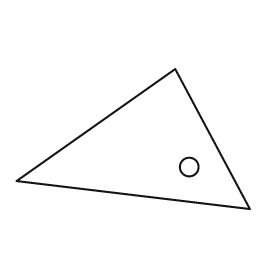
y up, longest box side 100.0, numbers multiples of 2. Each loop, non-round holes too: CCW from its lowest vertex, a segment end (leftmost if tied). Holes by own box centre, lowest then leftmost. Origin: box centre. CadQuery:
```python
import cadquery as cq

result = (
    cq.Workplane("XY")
    .moveTo(50.0, -30.0)
    .lineTo(18.0, 30.0)
    .lineTo(-50.0, -18.0)
    .close()
    .moveTo(24.0, -12.0)
    .circle(4.0)
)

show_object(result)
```